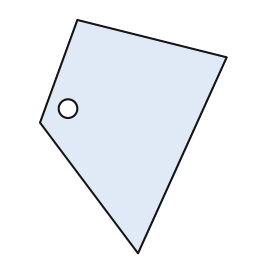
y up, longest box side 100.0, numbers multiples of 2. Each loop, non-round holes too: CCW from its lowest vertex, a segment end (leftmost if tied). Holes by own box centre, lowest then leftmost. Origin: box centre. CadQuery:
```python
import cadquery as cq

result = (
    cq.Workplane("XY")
    .moveTo(2.0, -50.0)
    .lineTo(40.0, 34.0)
    .lineTo(-24.0, 50.0)
    .lineTo(-40.0, 6.0)
    .close()
    .moveTo(-28.0, 12.0)
    .circle(4.0)
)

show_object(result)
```